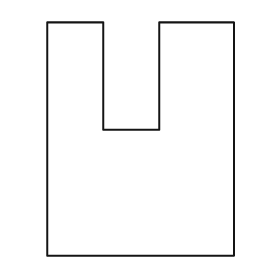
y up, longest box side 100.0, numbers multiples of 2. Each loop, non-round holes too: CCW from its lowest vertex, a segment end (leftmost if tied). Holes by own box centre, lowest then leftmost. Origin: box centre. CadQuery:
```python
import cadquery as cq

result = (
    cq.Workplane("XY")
    .moveTo(-40.0, -50.0)
    .lineTo(40.0, -50.0)
    .lineTo(40.0, 50.0)
    .lineTo(8.0, 50.0)
    .lineTo(8.0, 4.0)
    .lineTo(-16.0, 4.0)
    .lineTo(-16.0, 50.0)
    .lineTo(-40.0, 50.0)
    .close()
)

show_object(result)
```